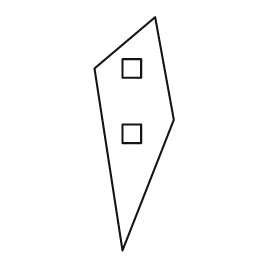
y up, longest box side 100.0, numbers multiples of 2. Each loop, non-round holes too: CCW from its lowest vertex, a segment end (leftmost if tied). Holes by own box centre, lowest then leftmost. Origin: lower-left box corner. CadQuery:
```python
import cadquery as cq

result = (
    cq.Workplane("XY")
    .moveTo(12.0, 0.0)
    .lineTo(34.0, 56.0)
    .lineTo(26.0, 100.0)
    .lineTo(0.0, 78.0)
    .close()
    .moveTo(12.0, 46.0)
    .lineTo(20.0, 46.0)
    .lineTo(20.0, 54.0)
    .lineTo(12.0, 54.0)
    .close()
    .moveTo(12.0, 74.0)
    .lineTo(20.0, 74.0)
    .lineTo(20.0, 82.0)
    .lineTo(12.0, 82.0)
    .close()
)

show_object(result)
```